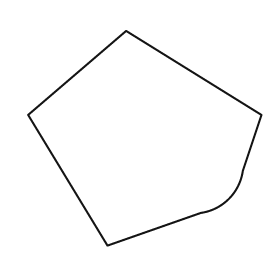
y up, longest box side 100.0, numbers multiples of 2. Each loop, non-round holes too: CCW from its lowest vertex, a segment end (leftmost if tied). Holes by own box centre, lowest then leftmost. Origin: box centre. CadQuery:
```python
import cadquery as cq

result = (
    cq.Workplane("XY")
    .moveTo(-16.0, -46.0)
    .lineTo(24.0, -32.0)
    .threePointArc((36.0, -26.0), (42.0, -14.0))
    .lineTo(50.0, 10.0)
    .lineTo(-8.0, 46.0)
    .lineTo(-50.0, 10.0)
    .close()
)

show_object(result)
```